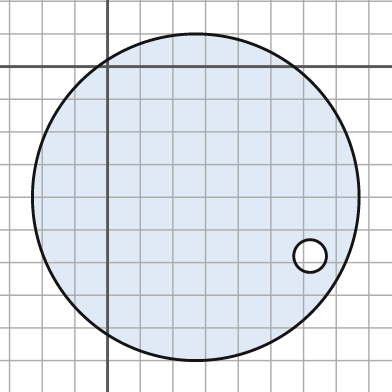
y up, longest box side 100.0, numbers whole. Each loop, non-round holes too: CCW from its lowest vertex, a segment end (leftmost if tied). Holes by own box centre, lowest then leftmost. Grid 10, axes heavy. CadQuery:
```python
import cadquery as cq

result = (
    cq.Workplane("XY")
    .moveTo(27.0, -40.0)
    .circle(50.0)
    .moveTo(62.0, -58.0)
    .circle(5.0)
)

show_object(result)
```